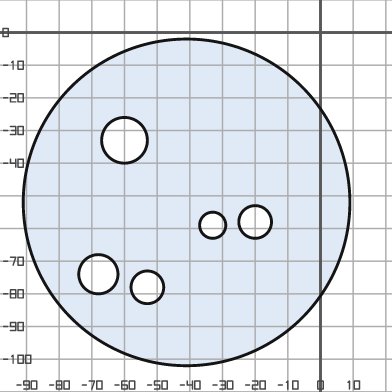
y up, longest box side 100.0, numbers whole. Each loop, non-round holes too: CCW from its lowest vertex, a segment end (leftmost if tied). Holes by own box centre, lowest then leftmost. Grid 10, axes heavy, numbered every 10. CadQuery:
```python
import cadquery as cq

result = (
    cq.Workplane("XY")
    .moveTo(-41.0, -52.0)
    .circle(50.0)
    .moveTo(-53.0, -78.0)
    .circle(5.0)
    .moveTo(-68.0, -74.0)
    .circle(6.0)
    .moveTo(-33.0, -59.0)
    .circle(4.0)
    .moveTo(-20.0, -58.0)
    .circle(5.0)
    .moveTo(-60.0, -33.0)
    .circle(7.0)
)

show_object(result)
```